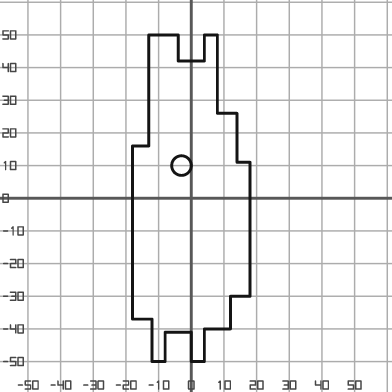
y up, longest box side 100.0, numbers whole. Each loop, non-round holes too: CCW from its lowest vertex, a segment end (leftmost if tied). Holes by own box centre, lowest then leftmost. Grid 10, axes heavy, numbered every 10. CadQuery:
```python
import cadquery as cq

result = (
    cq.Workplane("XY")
    .moveTo(-12.0, -50.0)
    .lineTo(-8.0, -50.0)
    .lineTo(-8.0, -41.0)
    .lineTo(0.0, -41.0)
    .lineTo(0.0, -50.0)
    .lineTo(4.0, -50.0)
    .lineTo(4.0, -40.0)
    .lineTo(12.0, -40.0)
    .lineTo(12.0, -30.0)
    .lineTo(18.0, -30.0)
    .lineTo(18.0, 11.0)
    .lineTo(14.0, 11.0)
    .lineTo(14.0, 26.0)
    .lineTo(8.0, 26.0)
    .lineTo(8.0, 50.0)
    .lineTo(4.0, 50.0)
    .lineTo(4.0, 42.0)
    .lineTo(-4.0, 42.0)
    .lineTo(-4.0, 50.0)
    .lineTo(-13.0, 50.0)
    .lineTo(-13.0, 16.0)
    .lineTo(-18.0, 16.0)
    .lineTo(-18.0, -37.0)
    .lineTo(-12.0, -37.0)
    .close()
    .moveTo(-3.0, 10.0)
    .circle(3.0)
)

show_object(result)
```